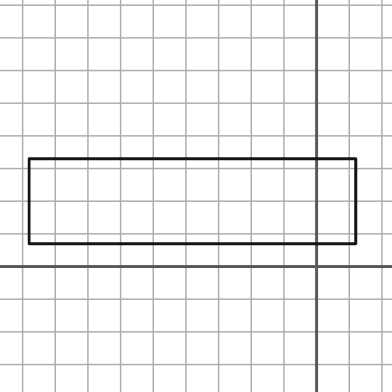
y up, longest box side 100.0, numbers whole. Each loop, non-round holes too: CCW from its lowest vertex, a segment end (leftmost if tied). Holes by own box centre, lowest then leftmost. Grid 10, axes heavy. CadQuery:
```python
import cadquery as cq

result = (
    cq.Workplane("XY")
    .moveTo(-88.0, 7.0)
    .lineTo(12.0, 7.0)
    .lineTo(12.0, 33.0)
    .lineTo(-88.0, 33.0)
    .close()
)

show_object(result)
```